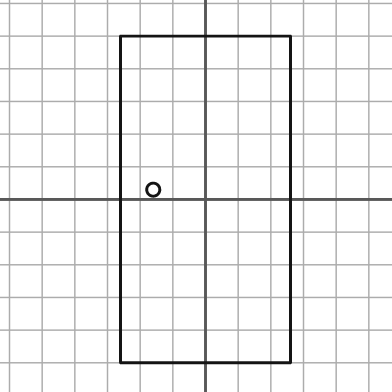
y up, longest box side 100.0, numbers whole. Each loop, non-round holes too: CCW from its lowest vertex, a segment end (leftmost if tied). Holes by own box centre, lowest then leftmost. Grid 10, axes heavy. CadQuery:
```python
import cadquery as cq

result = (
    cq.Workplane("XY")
    .moveTo(-26.0, -50.0)
    .lineTo(26.0, -50.0)
    .lineTo(26.0, 50.0)
    .lineTo(-26.0, 50.0)
    .close()
    .moveTo(-16.0, 3.0)
    .circle(2.0)
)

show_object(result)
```